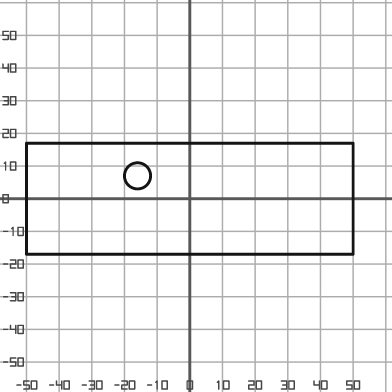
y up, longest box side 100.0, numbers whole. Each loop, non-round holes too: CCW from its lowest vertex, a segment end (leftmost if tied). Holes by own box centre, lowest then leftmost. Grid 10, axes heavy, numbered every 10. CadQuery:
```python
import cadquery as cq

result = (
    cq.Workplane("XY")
    .moveTo(-50.0, -17.0)
    .lineTo(50.0, -17.0)
    .lineTo(50.0, 17.0)
    .lineTo(-50.0, 17.0)
    .close()
    .moveTo(-16.0, 7.0)
    .circle(4.0)
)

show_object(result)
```